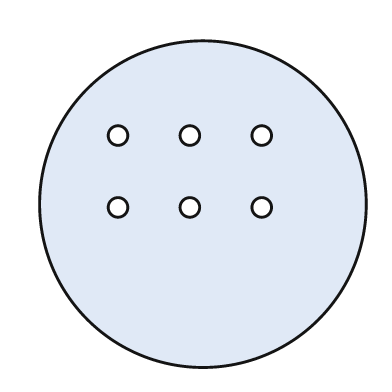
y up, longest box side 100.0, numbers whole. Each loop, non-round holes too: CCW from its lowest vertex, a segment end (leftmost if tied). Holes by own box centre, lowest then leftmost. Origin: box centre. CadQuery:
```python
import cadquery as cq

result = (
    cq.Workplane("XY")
    .moveTo(0.0, 0.0)
    .circle(50.0)
    .moveTo(-26.0, -1.0)
    .circle(3.0)
    .moveTo(-4.0, -1.0)
    .circle(3.0)
    .moveTo(18.0, -1.0)
    .circle(3.0)
    .moveTo(-26.0, 21.0)
    .circle(3.0)
    .moveTo(-4.0, 21.0)
    .circle(3.0)
    .moveTo(18.0, 21.0)
    .circle(3.0)
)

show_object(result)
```